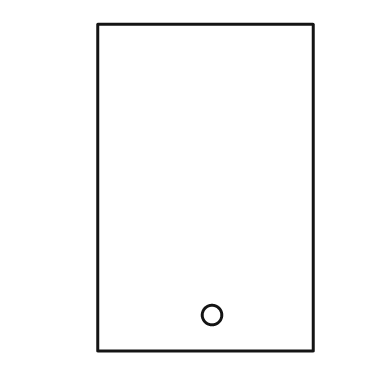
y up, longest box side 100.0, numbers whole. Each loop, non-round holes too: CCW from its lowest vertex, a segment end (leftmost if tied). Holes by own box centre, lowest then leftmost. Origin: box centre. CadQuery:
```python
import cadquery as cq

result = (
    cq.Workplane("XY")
    .moveTo(-33.0, -50.0)
    .lineTo(33.0, -50.0)
    .lineTo(33.0, 50.0)
    .lineTo(-33.0, 50.0)
    .close()
    .moveTo(2.0, -39.0)
    .circle(3.0)
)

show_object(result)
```